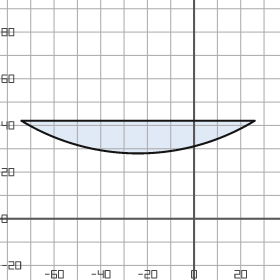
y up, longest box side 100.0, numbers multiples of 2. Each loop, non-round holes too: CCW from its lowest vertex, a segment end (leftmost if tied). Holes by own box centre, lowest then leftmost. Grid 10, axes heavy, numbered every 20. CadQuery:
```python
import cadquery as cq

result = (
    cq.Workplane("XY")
    .moveTo(-74.0, 42.0)
    .threePointArc((-24.0, 28.0), (26.0, 42.0))
    .close()
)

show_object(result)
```